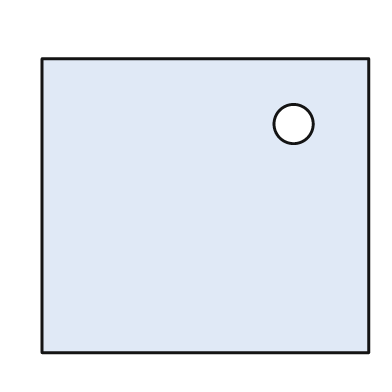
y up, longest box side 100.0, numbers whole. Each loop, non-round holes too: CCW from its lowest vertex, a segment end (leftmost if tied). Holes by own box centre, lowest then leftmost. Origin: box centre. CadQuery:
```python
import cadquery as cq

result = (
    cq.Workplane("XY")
    .moveTo(-50.0, -45.0)
    .lineTo(50.0, -45.0)
    .lineTo(50.0, 45.0)
    .lineTo(-50.0, 45.0)
    .close()
    .moveTo(27.0, 25.0)
    .circle(6.0)
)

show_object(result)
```